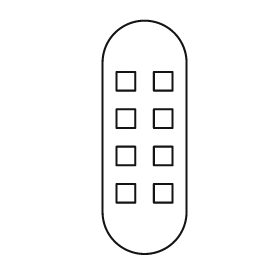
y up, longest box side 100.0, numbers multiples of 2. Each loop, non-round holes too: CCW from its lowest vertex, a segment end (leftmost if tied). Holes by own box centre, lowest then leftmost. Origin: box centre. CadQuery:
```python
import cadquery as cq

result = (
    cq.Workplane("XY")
    .moveTo(-18.0, -32.0)
    .threePointArc((0.0, -50.0), (18.0, -32.0))
    .lineTo(18.0, 32.0)
    .threePointArc((0.0, 50.0), (-18.0, 32.0))
    .close()
    .moveTo(-12.0, -28.0)
    .lineTo(-4.0, -28.0)
    .lineTo(-4.0, -20.0)
    .lineTo(-12.0, -20.0)
    .close()
    .moveTo(4.0, -28.0)
    .lineTo(12.0, -28.0)
    .lineTo(12.0, -20.0)
    .lineTo(4.0, -20.0)
    .close()
    .moveTo(-12.0, -12.0)
    .lineTo(-4.0, -12.0)
    .lineTo(-4.0, -4.0)
    .lineTo(-12.0, -4.0)
    .close()
    .moveTo(4.0, -12.0)
    .lineTo(12.0, -12.0)
    .lineTo(12.0, -4.0)
    .lineTo(4.0, -4.0)
    .close()
    .moveTo(-12.0, 4.0)
    .lineTo(-4.0, 4.0)
    .lineTo(-4.0, 12.0)
    .lineTo(-12.0, 12.0)
    .close()
    .moveTo(4.0, 4.0)
    .lineTo(12.0, 4.0)
    .lineTo(12.0, 12.0)
    .lineTo(4.0, 12.0)
    .close()
    .moveTo(-12.0, 20.0)
    .lineTo(-4.0, 20.0)
    .lineTo(-4.0, 28.0)
    .lineTo(-12.0, 28.0)
    .close()
    .moveTo(4.0, 20.0)
    .lineTo(12.0, 20.0)
    .lineTo(12.0, 28.0)
    .lineTo(4.0, 28.0)
    .close()
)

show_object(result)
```